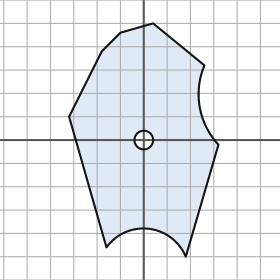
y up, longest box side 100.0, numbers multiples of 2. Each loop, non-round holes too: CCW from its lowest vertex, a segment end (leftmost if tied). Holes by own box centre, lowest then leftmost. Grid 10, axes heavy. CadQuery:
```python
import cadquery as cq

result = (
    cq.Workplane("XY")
    .moveTo(18.0, -50.0)
    .lineTo(32.0, -2.0)
    .threePointArc((24.0, 14.0), (26.0, 32.0))
    .lineTo(4.0, 50.0)
    .lineTo(-10.0, 46.0)
    .lineTo(-18.0, 38.0)
    .lineTo(-32.0, 10.0)
    .lineTo(-16.0, -46.0)
    .threePointArc((2.0, -38.0), (18.0, -50.0))
    .close()
    .moveTo(0.0, 0.0)
    .circle(4.0)
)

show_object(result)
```